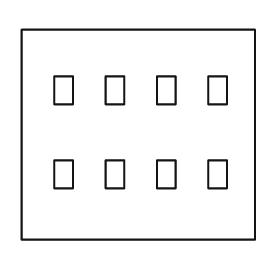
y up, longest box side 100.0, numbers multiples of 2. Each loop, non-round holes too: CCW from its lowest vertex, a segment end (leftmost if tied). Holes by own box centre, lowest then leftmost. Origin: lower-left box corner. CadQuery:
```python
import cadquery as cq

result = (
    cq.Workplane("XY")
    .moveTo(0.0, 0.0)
    .lineTo(100.0, 0.0)
    .lineTo(100.0, 90.0)
    .lineTo(0.0, 90.0)
    .close()
    .moveTo(14.0, 22.0)
    .lineTo(22.0, 22.0)
    .lineTo(22.0, 34.0)
    .lineTo(14.0, 34.0)
    .close()
    .moveTo(36.0, 22.0)
    .lineTo(44.0, 22.0)
    .lineTo(44.0, 34.0)
    .lineTo(36.0, 34.0)
    .close()
    .moveTo(58.0, 22.0)
    .lineTo(66.0, 22.0)
    .lineTo(66.0, 34.0)
    .lineTo(58.0, 34.0)
    .close()
    .moveTo(80.0, 22.0)
    .lineTo(88.0, 22.0)
    .lineTo(88.0, 34.0)
    .lineTo(80.0, 34.0)
    .close()
    .moveTo(14.0, 58.0)
    .lineTo(22.0, 58.0)
    .lineTo(22.0, 70.0)
    .lineTo(14.0, 70.0)
    .close()
    .moveTo(36.0, 58.0)
    .lineTo(44.0, 58.0)
    .lineTo(44.0, 70.0)
    .lineTo(36.0, 70.0)
    .close()
    .moveTo(58.0, 58.0)
    .lineTo(66.0, 58.0)
    .lineTo(66.0, 70.0)
    .lineTo(58.0, 70.0)
    .close()
    .moveTo(80.0, 58.0)
    .lineTo(88.0, 58.0)
    .lineTo(88.0, 70.0)
    .lineTo(80.0, 70.0)
    .close()
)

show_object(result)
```